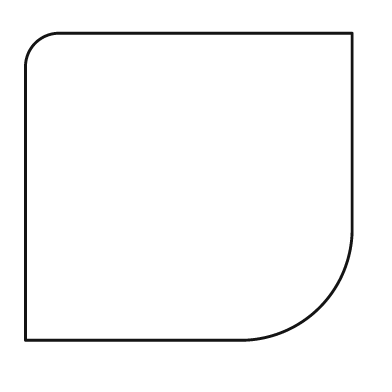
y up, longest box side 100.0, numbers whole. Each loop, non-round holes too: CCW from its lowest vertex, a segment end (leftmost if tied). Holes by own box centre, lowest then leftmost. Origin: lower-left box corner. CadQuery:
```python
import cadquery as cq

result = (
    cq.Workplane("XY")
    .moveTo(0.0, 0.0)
    .lineTo(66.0, 0.0)
    .threePointArc((90.0, 10.0), (100.0, 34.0))
    .lineTo(100.0, 94.0)
    .lineTo(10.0, 94.0)
    .threePointArc((3.0, 91.0), (0.0, 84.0))
    .close()
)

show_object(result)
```